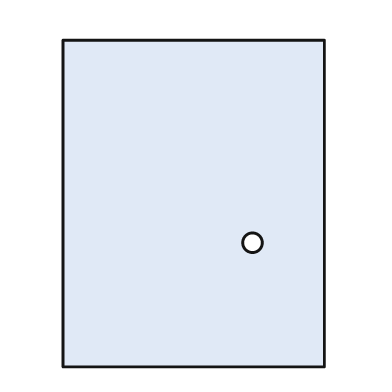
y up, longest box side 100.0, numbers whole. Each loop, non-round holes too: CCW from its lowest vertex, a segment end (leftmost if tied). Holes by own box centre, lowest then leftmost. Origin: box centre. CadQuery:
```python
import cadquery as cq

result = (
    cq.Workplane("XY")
    .moveTo(-40.0, -50.0)
    .lineTo(40.0, -50.0)
    .lineTo(40.0, 50.0)
    .lineTo(-40.0, 50.0)
    .close()
    .moveTo(18.0, -12.0)
    .circle(3.0)
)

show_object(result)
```